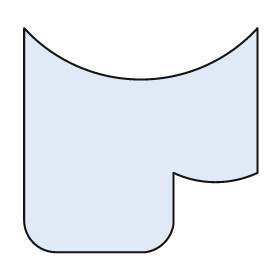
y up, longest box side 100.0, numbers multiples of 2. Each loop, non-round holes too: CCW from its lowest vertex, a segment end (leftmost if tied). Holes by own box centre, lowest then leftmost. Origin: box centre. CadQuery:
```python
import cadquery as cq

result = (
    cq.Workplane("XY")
    .moveTo(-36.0, -48.0)
    .lineTo(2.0, -48.0)
    .threePointArc((10.0, -44.0), (14.0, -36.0))
    .lineTo(14.0, -14.0)
    .threePointArc((32.0, -18.0), (50.0, -14.0))
    .lineTo(50.0, 48.0)
    .threePointArc((0.0, 26.0), (-50.0, 48.0))
    .lineTo(-50.0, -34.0)
    .threePointArc((-46.0, -44.0), (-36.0, -48.0))
    .close()
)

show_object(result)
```